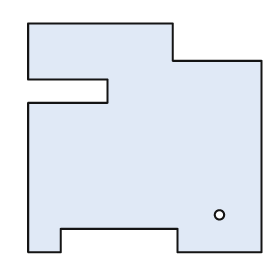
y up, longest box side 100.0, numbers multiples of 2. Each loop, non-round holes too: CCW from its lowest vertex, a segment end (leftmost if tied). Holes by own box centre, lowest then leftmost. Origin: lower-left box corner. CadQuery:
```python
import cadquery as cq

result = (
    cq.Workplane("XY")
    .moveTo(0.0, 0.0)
    .lineTo(14.0, 0.0)
    .lineTo(14.0, 10.0)
    .lineTo(64.0, 10.0)
    .lineTo(64.0, 0.0)
    .lineTo(100.0, 0.0)
    .lineTo(100.0, 82.0)
    .lineTo(62.0, 82.0)
    .lineTo(62.0, 98.0)
    .lineTo(0.0, 98.0)
    .lineTo(0.0, 74.0)
    .lineTo(34.0, 74.0)
    .lineTo(34.0, 64.0)
    .lineTo(0.0, 64.0)
    .close()
    .moveTo(82.0, 16.0)
    .circle(2.0)
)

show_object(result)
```